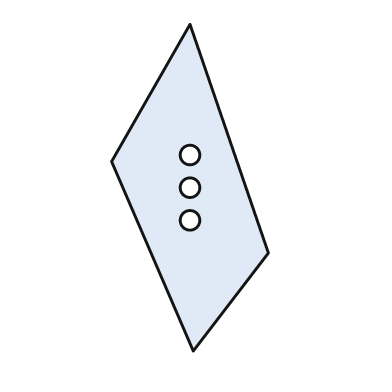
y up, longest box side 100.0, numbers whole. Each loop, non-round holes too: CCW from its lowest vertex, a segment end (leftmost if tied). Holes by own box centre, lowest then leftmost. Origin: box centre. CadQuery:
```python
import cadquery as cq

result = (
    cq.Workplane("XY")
    .moveTo(1.0, -50.0)
    .lineTo(24.0, -20.0)
    .lineTo(0.0, 50.0)
    .lineTo(-24.0, 8.0)
    .close()
    .moveTo(0.0, -10.0)
    .circle(3.0)
    .moveTo(0.0, 0.0)
    .circle(3.0)
    .moveTo(0.0, 10.0)
    .circle(3.0)
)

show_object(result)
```